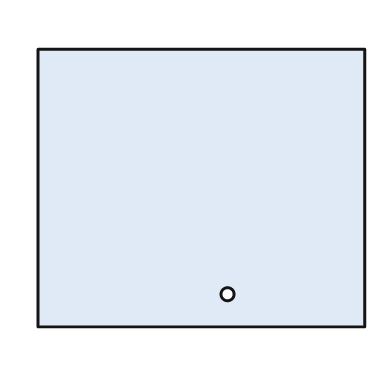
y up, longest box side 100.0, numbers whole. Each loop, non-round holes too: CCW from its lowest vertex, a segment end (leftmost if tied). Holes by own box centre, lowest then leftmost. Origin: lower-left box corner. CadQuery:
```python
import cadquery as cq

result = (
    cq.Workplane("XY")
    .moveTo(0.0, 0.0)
    .lineTo(100.0, 0.0)
    .lineTo(100.0, 85.0)
    .lineTo(0.0, 85.0)
    .close()
    .moveTo(58.0, 10.0)
    .circle(2.0)
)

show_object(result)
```